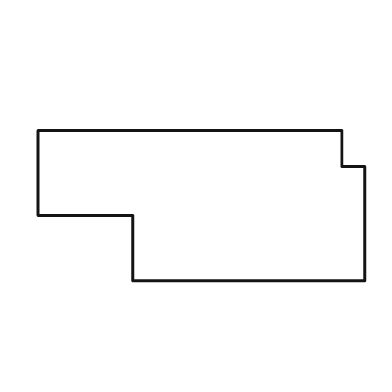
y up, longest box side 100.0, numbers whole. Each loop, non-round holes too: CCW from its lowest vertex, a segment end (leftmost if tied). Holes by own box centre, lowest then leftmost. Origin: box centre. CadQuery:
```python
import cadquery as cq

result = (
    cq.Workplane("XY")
    .moveTo(-21.0, -23.0)
    .lineTo(50.0, -23.0)
    .lineTo(50.0, 12.0)
    .lineTo(43.0, 12.0)
    .lineTo(43.0, 23.0)
    .lineTo(-50.0, 23.0)
    .lineTo(-50.0, -3.0)
    .lineTo(-21.0, -3.0)
    .close()
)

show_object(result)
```